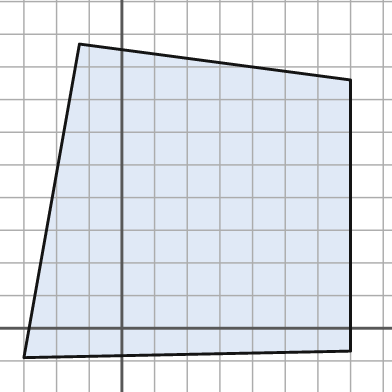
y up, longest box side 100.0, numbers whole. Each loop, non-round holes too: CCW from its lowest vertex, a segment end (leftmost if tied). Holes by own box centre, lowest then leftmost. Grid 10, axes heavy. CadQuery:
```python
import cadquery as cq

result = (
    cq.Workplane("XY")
    .moveTo(-30.0, -9.0)
    .lineTo(70.0, -7.0)
    .lineTo(70.0, 76.0)
    .lineTo(-13.0, 87.0)
    .close()
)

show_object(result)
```